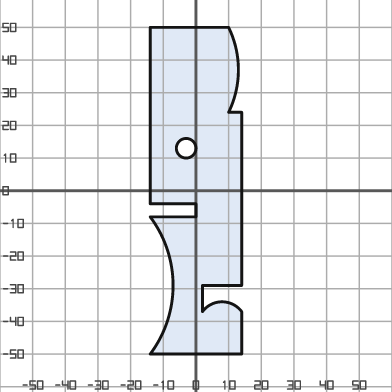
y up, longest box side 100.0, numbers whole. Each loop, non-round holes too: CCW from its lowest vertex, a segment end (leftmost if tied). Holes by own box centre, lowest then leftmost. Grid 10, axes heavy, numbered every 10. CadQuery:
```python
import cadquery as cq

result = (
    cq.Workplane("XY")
    .moveTo(-14.0, -50.0)
    .lineTo(14.0, -50.0)
    .lineTo(14.0, -37.0)
    .threePointArc((8.0, -34.0), (2.0, -37.0))
    .lineTo(2.0, -29.0)
    .lineTo(14.0, -29.0)
    .lineTo(14.0, 24.0)
    .lineTo(10.0, 24.0)
    .threePointArc((13.0, 37.0), (10.0, 50.0))
    .lineTo(-14.0, 50.0)
    .lineTo(-14.0, -4.0)
    .lineTo(0.0, -4.0)
    .lineTo(0.0, -8.0)
    .lineTo(-14.0, -8.0)
    .threePointArc((-7.0, -29.0), (-14.0, -50.0))
    .close()
    .moveTo(-3.0, 13.0)
    .circle(3.0)
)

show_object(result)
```